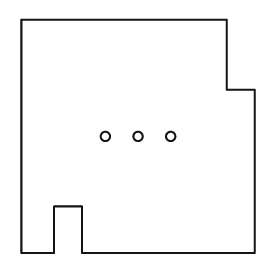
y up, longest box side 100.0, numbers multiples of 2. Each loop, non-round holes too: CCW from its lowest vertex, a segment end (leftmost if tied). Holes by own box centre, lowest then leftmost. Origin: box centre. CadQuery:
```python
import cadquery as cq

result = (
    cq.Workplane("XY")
    .moveTo(-50.0, -50.0)
    .lineTo(-36.0, -50.0)
    .lineTo(-36.0, -30.0)
    .lineTo(-24.0, -30.0)
    .lineTo(-24.0, -50.0)
    .lineTo(50.0, -50.0)
    .lineTo(50.0, 20.0)
    .lineTo(38.0, 20.0)
    .lineTo(38.0, 50.0)
    .lineTo(-50.0, 50.0)
    .close()
    .moveTo(-14.0, 0.0)
    .circle(2.0)
    .moveTo(0.0, 0.0)
    .circle(2.0)
    .moveTo(14.0, 0.0)
    .circle(2.0)
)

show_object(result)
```